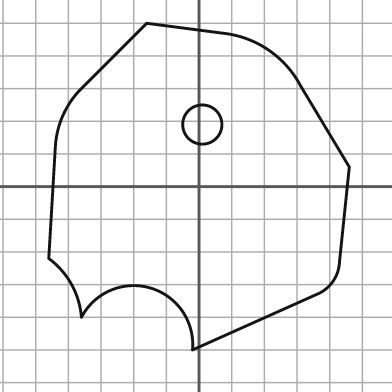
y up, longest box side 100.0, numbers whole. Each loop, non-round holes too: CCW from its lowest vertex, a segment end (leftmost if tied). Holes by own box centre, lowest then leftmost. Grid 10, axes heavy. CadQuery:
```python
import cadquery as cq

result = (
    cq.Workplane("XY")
    .moveTo(-2.0, -50.0)
    .lineTo(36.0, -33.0)
    .threePointArc((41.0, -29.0), (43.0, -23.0))
    .lineTo(46.0, 6.0)
    .lineTo(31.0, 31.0)
    .threePointArc((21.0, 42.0), (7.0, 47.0))
    .lineTo(-16.0, 50.0)
    .lineTo(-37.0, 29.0)
    .threePointArc((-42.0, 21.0), (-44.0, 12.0))
    .lineTo(-46.0, -22.0)
    .threePointArc((-39.0, -30.0), (-36.0, -40.0))
    .threePointArc((-15.0, -31.0), (-2.0, -50.0))
    .close()
    .moveTo(1.0, 19.0)
    .circle(6.0)
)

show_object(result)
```